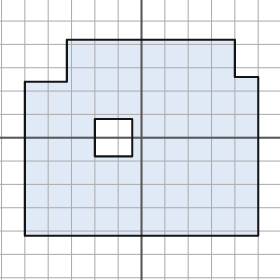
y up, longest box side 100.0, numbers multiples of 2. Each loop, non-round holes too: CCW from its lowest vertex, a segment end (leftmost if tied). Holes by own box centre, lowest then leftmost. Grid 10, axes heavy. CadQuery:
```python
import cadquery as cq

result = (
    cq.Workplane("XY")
    .moveTo(-50.0, -42.0)
    .lineTo(50.0, -42.0)
    .lineTo(50.0, 26.0)
    .lineTo(40.0, 26.0)
    .lineTo(40.0, 42.0)
    .lineTo(-32.0, 42.0)
    .lineTo(-32.0, 24.0)
    .lineTo(-50.0, 24.0)
    .close()
    .moveTo(-20.0, -8.0)
    .lineTo(-4.0, -8.0)
    .lineTo(-4.0, 8.0)
    .lineTo(-20.0, 8.0)
    .close()
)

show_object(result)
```